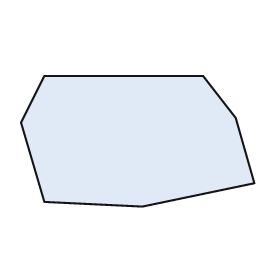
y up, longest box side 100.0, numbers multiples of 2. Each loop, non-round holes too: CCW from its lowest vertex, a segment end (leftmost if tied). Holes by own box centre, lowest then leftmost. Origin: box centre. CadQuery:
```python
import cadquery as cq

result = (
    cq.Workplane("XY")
    .moveTo(2.0, -28.0)
    .lineTo(50.0, -18.0)
    .lineTo(42.0, 10.0)
    .lineTo(28.0, 28.0)
    .lineTo(-40.0, 28.0)
    .lineTo(-50.0, 8.0)
    .lineTo(-40.0, -26.0)
    .close()
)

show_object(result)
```